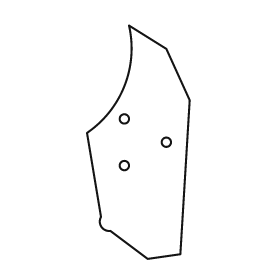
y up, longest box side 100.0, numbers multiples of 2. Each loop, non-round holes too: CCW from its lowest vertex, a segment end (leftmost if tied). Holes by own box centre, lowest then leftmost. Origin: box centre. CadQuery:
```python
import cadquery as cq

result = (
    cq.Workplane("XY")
    .moveTo(4.0, -50.0)
    .lineTo(18.0, -48.0)
    .lineTo(22.0, 18.0)
    .lineTo(12.0, 40.0)
    .lineTo(-4.0, 50.0)
    .threePointArc((-6.0, 24.0), (-22.0, 4.0))
    .lineTo(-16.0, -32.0)
    .threePointArc((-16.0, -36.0), (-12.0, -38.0))
    .close()
    .moveTo(-6.0, -10.0)
    .circle(2.0)
    .moveTo(12.0, 0.0)
    .circle(2.0)
    .moveTo(-6.0, 10.0)
    .circle(2.0)
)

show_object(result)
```